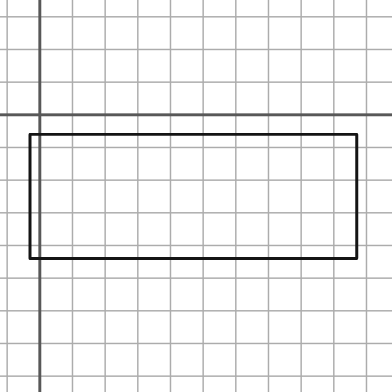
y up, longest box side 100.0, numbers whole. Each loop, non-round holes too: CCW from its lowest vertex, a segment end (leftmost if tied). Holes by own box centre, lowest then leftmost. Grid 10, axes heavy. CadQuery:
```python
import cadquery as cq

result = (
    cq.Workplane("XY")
    .moveTo(-3.0, -44.0)
    .lineTo(97.0, -44.0)
    .lineTo(97.0, -6.0)
    .lineTo(-3.0, -6.0)
    .close()
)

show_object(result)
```